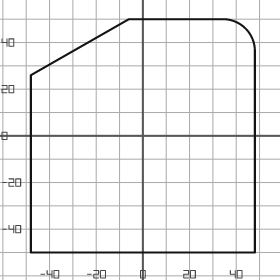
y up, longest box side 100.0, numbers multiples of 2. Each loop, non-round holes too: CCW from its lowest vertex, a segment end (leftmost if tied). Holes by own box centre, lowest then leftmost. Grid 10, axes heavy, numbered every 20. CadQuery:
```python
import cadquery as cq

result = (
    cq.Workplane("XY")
    .moveTo(-48.0, -50.0)
    .lineTo(48.0, -50.0)
    .lineTo(48.0, 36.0)
    .threePointArc((44.0, 46.0), (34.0, 50.0))
    .lineTo(-6.0, 50.0)
    .lineTo(-48.0, 26.0)
    .close()
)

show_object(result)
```